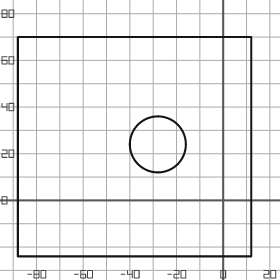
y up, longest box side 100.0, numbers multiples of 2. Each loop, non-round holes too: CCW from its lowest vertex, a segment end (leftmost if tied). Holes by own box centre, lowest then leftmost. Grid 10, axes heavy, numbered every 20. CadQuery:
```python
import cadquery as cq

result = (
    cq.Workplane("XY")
    .moveTo(-88.0, -24.0)
    .lineTo(12.0, -24.0)
    .lineTo(12.0, 70.0)
    .lineTo(-88.0, 70.0)
    .close()
    .moveTo(-28.0, 24.0)
    .circle(12.0)
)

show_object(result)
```